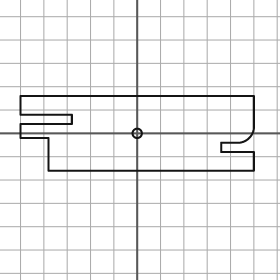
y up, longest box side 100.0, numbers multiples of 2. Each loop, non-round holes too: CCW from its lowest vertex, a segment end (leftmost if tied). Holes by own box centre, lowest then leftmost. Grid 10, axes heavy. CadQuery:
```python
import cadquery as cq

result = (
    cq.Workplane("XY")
    .moveTo(-38.0, -16.0)
    .lineTo(50.0, -16.0)
    .lineTo(50.0, -8.0)
    .lineTo(36.0, -8.0)
    .lineTo(36.0, -4.0)
    .lineTo(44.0, -4.0)
    .threePointArc((48.0, -2.0), (50.0, 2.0))
    .lineTo(50.0, 16.0)
    .lineTo(-50.0, 16.0)
    .lineTo(-50.0, 8.0)
    .lineTo(-28.0, 8.0)
    .lineTo(-28.0, 4.0)
    .lineTo(-50.0, 4.0)
    .lineTo(-50.0, -2.0)
    .lineTo(-38.0, -2.0)
    .close()
    .moveTo(0.0, 0.0)
    .circle(2.0)
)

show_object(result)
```